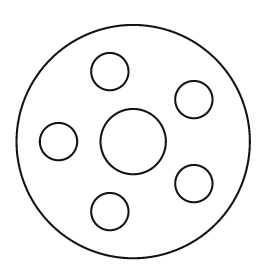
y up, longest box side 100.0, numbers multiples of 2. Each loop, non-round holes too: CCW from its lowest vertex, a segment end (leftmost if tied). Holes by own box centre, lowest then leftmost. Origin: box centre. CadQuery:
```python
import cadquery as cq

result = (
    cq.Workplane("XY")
    .moveTo(0.0, 0.0)
    .circle(50.0)
    .moveTo(-10.0, -30.0)
    .circle(8.0)
    .moveTo(26.0, -18.0)
    .circle(8.0)
    .moveTo(-32.0, 0.0)
    .circle(8.0)
    .moveTo(0.0, 0.0)
    .circle(14.0)
    .moveTo(26.0, 18.0)
    .circle(8.0)
    .moveTo(-10.0, 30.0)
    .circle(8.0)
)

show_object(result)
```